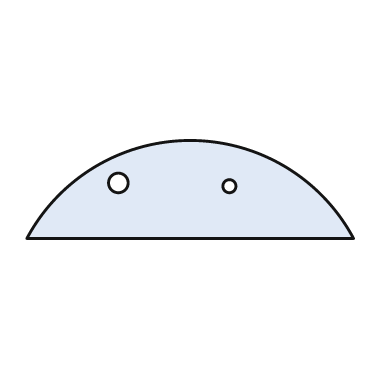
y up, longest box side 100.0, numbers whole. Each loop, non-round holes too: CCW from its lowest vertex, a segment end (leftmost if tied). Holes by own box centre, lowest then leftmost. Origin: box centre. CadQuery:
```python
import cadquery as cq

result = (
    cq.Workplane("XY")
    .moveTo(-50.0, -15.0)
    .lineTo(50.0, -15.0)
    .threePointArc((0.0, 15.0), (-50.0, -15.0))
    .close()
    .moveTo(12.0, 1.0)
    .circle(2.0)
    .moveTo(-22.0, 2.0)
    .circle(3.0)
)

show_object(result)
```